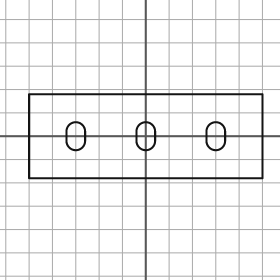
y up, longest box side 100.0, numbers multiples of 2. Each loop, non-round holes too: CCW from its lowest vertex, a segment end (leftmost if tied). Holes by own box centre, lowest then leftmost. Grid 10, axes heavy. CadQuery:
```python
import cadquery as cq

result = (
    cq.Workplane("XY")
    .moveTo(-50.0, -18.0)
    .lineTo(50.0, -18.0)
    .lineTo(50.0, 18.0)
    .lineTo(-50.0, 18.0)
    .close()
    .moveTo(-34.0, -2.0)
    .threePointArc((-30.0, -6.0), (-26.0, -2.0))
    .lineTo(-26.0, 2.0)
    .threePointArc((-30.0, 6.0), (-34.0, 2.0))
    .close()
    .moveTo(-4.0, -2.0)
    .threePointArc((0.0, -6.0), (4.0, -2.0))
    .lineTo(4.0, 2.0)
    .threePointArc((0.0, 6.0), (-4.0, 2.0))
    .close()
    .moveTo(26.0, -2.0)
    .threePointArc((30.0, -6.0), (34.0, -2.0))
    .lineTo(34.0, 2.0)
    .threePointArc((30.0, 6.0), (26.0, 2.0))
    .close()
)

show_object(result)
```